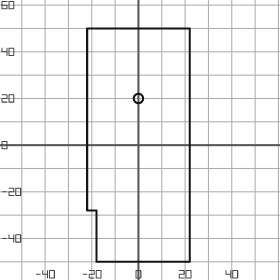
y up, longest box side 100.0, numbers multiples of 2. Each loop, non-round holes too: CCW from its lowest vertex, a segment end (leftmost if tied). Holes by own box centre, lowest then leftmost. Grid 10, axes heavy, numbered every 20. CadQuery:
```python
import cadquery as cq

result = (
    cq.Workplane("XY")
    .moveTo(-18.0, -50.0)
    .lineTo(22.0, -50.0)
    .lineTo(22.0, 50.0)
    .lineTo(-22.0, 50.0)
    .lineTo(-22.0, -28.0)
    .lineTo(-18.0, -28.0)
    .close()
    .moveTo(0.0, 20.0)
    .circle(2.0)
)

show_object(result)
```